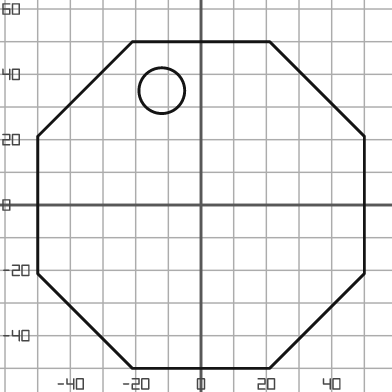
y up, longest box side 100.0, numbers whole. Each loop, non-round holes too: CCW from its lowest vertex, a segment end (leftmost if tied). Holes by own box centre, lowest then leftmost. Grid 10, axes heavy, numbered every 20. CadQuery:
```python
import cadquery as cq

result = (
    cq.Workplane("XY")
    .moveTo(-21.0, -50.0)
    .lineTo(21.0, -50.0)
    .lineTo(50.0, -21.0)
    .lineTo(50.0, 21.0)
    .lineTo(21.0, 50.0)
    .lineTo(-21.0, 50.0)
    .lineTo(-50.0, 21.0)
    .lineTo(-50.0, -21.0)
    .close()
    .moveTo(-12.0, 35.0)
    .circle(7.0)
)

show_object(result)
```